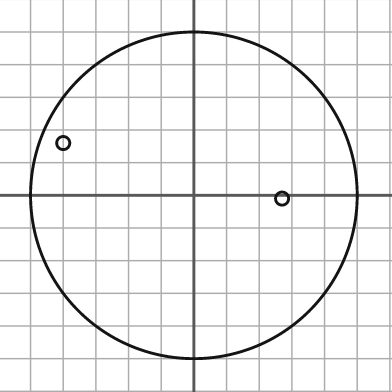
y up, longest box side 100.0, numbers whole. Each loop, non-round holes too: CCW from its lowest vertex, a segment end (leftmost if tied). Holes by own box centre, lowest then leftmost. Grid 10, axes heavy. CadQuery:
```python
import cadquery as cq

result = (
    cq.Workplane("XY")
    .moveTo(0.0, 0.0)
    .circle(50.0)
    .moveTo(27.0, -1.0)
    .circle(2.0)
    .moveTo(-40.0, 16.0)
    .circle(2.0)
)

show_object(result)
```